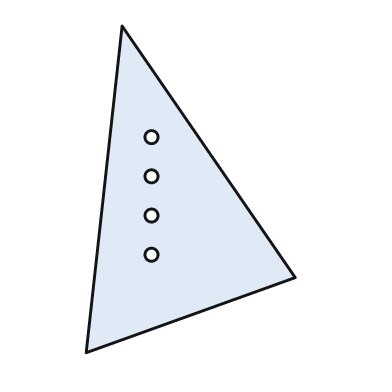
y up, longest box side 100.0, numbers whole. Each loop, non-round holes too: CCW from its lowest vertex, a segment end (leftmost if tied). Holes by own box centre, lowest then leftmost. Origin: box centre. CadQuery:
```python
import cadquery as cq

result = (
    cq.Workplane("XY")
    .moveTo(-32.0, -50.0)
    .lineTo(32.0, -27.0)
    .lineTo(-21.0, 50.0)
    .close()
    .moveTo(-12.0, -20.0)
    .circle(2.0)
    .moveTo(-12.0, -8.0)
    .circle(2.0)
    .moveTo(-12.0, 4.0)
    .circle(2.0)
    .moveTo(-12.0, 16.0)
    .circle(2.0)
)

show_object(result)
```